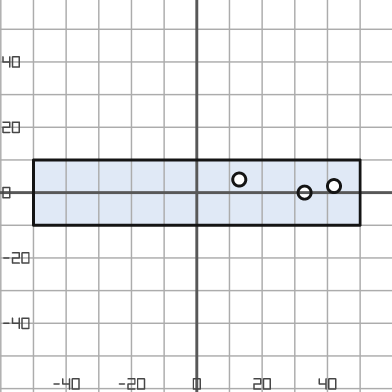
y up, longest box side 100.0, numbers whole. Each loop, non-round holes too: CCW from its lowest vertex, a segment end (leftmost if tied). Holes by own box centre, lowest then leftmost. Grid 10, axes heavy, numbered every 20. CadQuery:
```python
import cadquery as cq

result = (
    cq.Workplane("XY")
    .moveTo(-50.0, -10.0)
    .lineTo(50.0, -10.0)
    .lineTo(50.0, 10.0)
    .lineTo(-50.0, 10.0)
    .close()
    .moveTo(33.0, 0.0)
    .circle(2.0)
    .moveTo(42.0, 2.0)
    .circle(2.0)
    .moveTo(13.0, 4.0)
    .circle(2.0)
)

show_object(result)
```